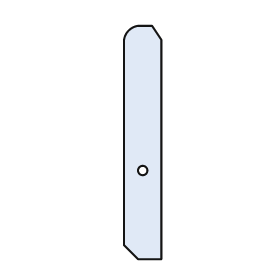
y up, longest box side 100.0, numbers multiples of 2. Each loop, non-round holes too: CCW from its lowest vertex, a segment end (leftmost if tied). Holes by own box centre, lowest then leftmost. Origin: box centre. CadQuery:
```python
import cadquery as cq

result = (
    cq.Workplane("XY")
    .moveTo(-2.0, -50.0)
    .lineTo(8.0, -50.0)
    .lineTo(8.0, 44.0)
    .lineTo(4.0, 50.0)
    .lineTo(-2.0, 50.0)
    .threePointArc((-6.0, 48.0), (-8.0, 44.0))
    .lineTo(-8.0, -44.0)
    .close()
    .moveTo(0.0, -12.0)
    .circle(2.0)
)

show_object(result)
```